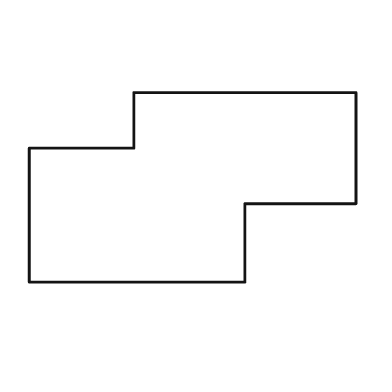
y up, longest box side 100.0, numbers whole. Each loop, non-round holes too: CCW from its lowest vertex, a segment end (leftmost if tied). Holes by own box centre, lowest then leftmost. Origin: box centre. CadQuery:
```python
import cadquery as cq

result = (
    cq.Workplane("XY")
    .moveTo(-50.0, -29.0)
    .lineTo(16.0, -29.0)
    .lineTo(16.0, -5.0)
    .lineTo(50.0, -5.0)
    .lineTo(50.0, 29.0)
    .lineTo(-18.0, 29.0)
    .lineTo(-18.0, 12.0)
    .lineTo(-50.0, 12.0)
    .close()
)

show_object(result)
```